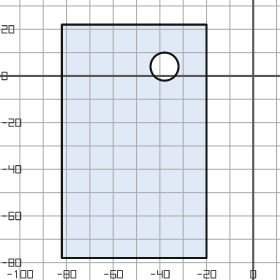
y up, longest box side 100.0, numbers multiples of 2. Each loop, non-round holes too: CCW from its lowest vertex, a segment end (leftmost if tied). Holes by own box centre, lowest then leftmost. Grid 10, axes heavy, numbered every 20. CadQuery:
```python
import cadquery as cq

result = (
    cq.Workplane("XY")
    .moveTo(-82.0, -78.0)
    .lineTo(-20.0, -78.0)
    .lineTo(-20.0, 22.0)
    .lineTo(-82.0, 22.0)
    .close()
    .moveTo(-38.0, 4.0)
    .circle(6.0)
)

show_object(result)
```